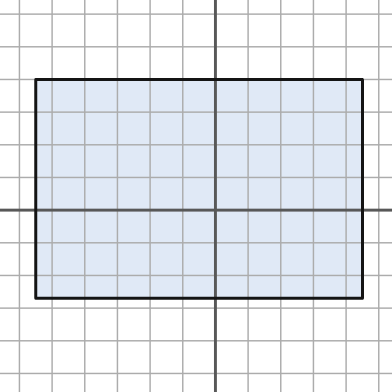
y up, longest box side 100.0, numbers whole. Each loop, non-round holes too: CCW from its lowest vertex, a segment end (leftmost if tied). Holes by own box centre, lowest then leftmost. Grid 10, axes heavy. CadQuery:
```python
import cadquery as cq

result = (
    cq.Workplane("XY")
    .moveTo(-55.0, -27.0)
    .lineTo(45.0, -27.0)
    .lineTo(45.0, 40.0)
    .lineTo(-55.0, 40.0)
    .close()
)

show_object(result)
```